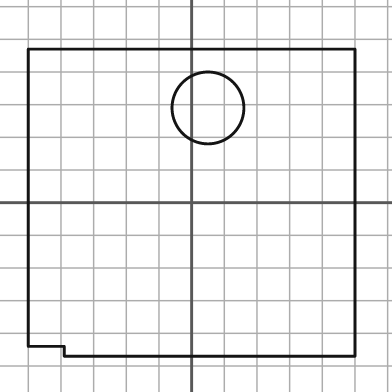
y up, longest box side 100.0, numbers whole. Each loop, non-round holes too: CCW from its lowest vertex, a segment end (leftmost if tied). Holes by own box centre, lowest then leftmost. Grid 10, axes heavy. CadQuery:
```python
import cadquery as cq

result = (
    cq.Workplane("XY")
    .moveTo(-39.0, -47.0)
    .lineTo(50.0, -47.0)
    .lineTo(50.0, 47.0)
    .lineTo(-50.0, 47.0)
    .lineTo(-50.0, -44.0)
    .lineTo(-39.0, -44.0)
    .close()
    .moveTo(5.0, 29.0)
    .circle(11.0)
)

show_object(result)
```